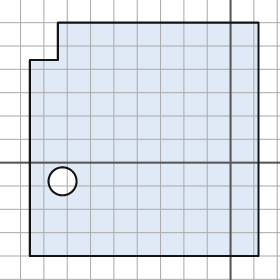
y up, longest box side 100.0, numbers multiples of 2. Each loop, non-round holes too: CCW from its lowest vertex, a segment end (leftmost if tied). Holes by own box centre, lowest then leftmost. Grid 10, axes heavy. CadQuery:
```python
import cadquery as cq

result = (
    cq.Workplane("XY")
    .moveTo(-86.0, -40.0)
    .lineTo(12.0, -40.0)
    .lineTo(12.0, 60.0)
    .lineTo(-74.0, 60.0)
    .lineTo(-74.0, 44.0)
    .lineTo(-86.0, 44.0)
    .close()
    .moveTo(-72.0, -8.0)
    .circle(6.0)
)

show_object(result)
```